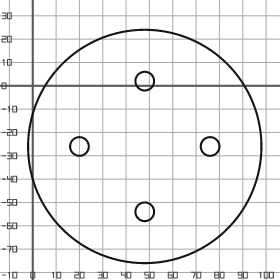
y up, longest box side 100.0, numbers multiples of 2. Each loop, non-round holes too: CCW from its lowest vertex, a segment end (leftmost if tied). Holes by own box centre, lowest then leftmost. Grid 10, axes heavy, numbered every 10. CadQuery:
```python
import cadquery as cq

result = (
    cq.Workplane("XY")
    .moveTo(48.0, -26.0)
    .circle(50.0)
    .moveTo(48.0, -54.0)
    .circle(4.0)
    .moveTo(20.0, -26.0)
    .circle(4.0)
    .moveTo(76.0, -26.0)
    .circle(4.0)
    .moveTo(48.0, 2.0)
    .circle(4.0)
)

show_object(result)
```